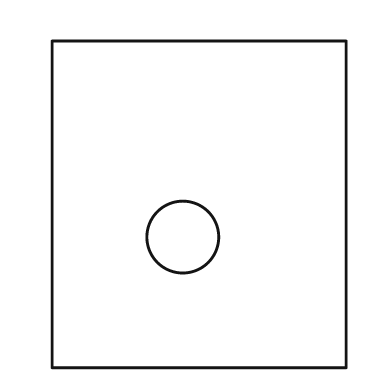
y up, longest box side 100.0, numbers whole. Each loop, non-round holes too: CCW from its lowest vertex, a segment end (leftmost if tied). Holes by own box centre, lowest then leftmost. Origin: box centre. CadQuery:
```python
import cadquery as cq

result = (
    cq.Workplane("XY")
    .moveTo(-45.0, -50.0)
    .lineTo(45.0, -50.0)
    .lineTo(45.0, 50.0)
    .lineTo(-45.0, 50.0)
    .close()
    .moveTo(-5.0, -10.0)
    .circle(11.0)
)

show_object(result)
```